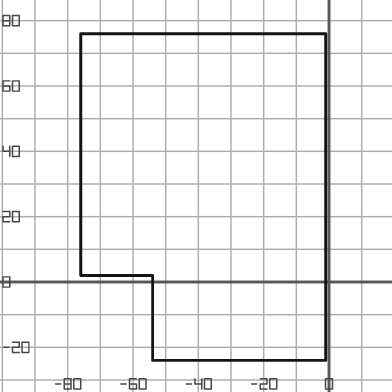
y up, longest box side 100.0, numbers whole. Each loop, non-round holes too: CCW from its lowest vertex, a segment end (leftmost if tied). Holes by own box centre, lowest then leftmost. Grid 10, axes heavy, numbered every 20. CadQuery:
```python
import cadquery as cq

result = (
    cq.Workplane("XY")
    .moveTo(-54.0, -24.0)
    .lineTo(-1.0, -24.0)
    .lineTo(-1.0, 76.0)
    .lineTo(-76.0, 76.0)
    .lineTo(-76.0, 2.0)
    .lineTo(-54.0, 2.0)
    .close()
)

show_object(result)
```